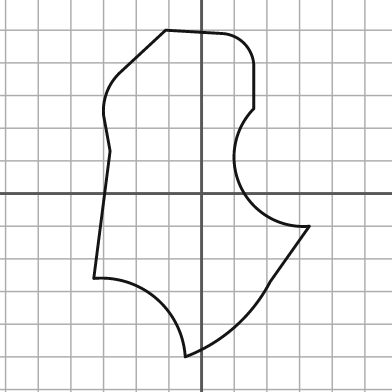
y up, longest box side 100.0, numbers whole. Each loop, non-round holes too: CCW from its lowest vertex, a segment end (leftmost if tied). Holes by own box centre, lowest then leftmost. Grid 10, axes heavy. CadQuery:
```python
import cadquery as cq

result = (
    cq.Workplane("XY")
    .moveTo(-5.0, -50.0)
    .threePointArc((10.0, -41.0), (21.0, -27.0))
    .lineTo(33.0, -10.0)
    .threePointArc((12.0, 2.0), (16.0, 26.0))
    .lineTo(16.0, 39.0)
    .threePointArc((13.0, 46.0), (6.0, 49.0))
    .lineTo(-11.0, 50.0)
    .lineTo(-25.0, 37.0)
    .threePointArc((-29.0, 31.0), (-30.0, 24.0))
    .lineTo(-28.0, 13.0)
    .lineTo(-33.0, -26.0)
    .threePointArc((-14.0, -32.0), (-5.0, -50.0))
    .close()
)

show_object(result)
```